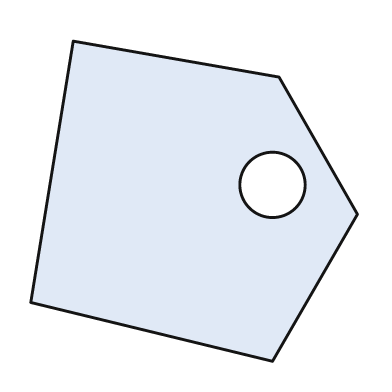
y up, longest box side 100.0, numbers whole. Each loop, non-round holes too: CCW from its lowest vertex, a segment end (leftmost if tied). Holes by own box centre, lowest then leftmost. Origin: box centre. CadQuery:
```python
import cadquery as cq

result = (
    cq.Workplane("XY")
    .moveTo(24.0, -49.0)
    .lineTo(50.0, -4.0)
    .lineTo(26.0, 38.0)
    .lineTo(-37.0, 49.0)
    .lineTo(-50.0, -31.0)
    .close()
    .moveTo(24.0, 5.0)
    .circle(10.0)
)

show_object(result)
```